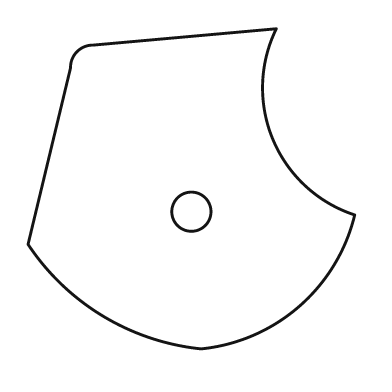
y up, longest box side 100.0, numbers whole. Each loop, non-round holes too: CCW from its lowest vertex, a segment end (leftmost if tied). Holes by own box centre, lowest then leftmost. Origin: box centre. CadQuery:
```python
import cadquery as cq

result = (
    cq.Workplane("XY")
    .moveTo(3.0, -49.0)
    .threePointArc((33.0, -36.0), (50.0, -8.0))
    .threePointArc((25.0, 15.0), (26.0, 49.0))
    .lineTo(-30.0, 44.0)
    .threePointArc((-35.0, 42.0), (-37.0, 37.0))
    .lineTo(-50.0, -17.0)
    .threePointArc((-27.0, -39.0), (3.0, -49.0))
    .close()
    .moveTo(0.0, -7.0)
    .circle(6.0)
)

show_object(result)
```